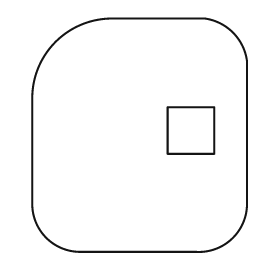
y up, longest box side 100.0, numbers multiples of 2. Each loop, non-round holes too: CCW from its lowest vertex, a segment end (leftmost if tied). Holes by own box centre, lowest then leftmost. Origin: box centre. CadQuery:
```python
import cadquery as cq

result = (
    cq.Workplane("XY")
    .moveTo(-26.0, -50.0)
    .lineTo(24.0, -50.0)
    .threePointArc((40.0, -44.0), (46.0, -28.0))
    .lineTo(46.0, 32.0)
    .threePointArc((40.0, 44.0), (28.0, 50.0))
    .lineTo(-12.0, 50.0)
    .threePointArc((-36.0, 40.0), (-46.0, 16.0))
    .lineTo(-46.0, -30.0)
    .threePointArc((-40.0, -44.0), (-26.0, -50.0))
    .close()
    .moveTo(12.0, -8.0)
    .lineTo(32.0, -8.0)
    .lineTo(32.0, 12.0)
    .lineTo(12.0, 12.0)
    .close()
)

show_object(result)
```